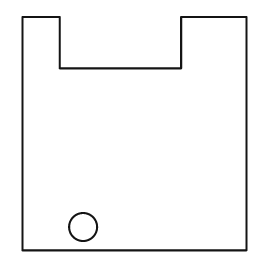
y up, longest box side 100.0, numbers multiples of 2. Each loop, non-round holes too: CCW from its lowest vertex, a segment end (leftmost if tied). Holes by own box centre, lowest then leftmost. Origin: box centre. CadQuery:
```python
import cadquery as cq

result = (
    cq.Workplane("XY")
    .moveTo(-48.0, -50.0)
    .lineTo(48.0, -50.0)
    .lineTo(48.0, 50.0)
    .lineTo(20.0, 50.0)
    .lineTo(20.0, 28.0)
    .lineTo(-32.0, 28.0)
    .lineTo(-32.0, 50.0)
    .lineTo(-48.0, 50.0)
    .close()
    .moveTo(-22.0, -40.0)
    .circle(6.0)
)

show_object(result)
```